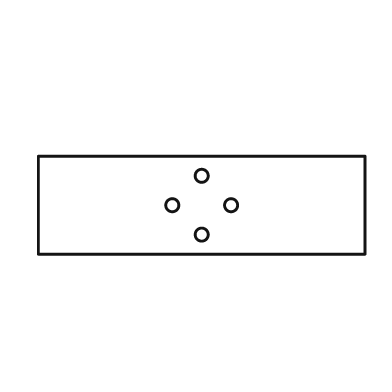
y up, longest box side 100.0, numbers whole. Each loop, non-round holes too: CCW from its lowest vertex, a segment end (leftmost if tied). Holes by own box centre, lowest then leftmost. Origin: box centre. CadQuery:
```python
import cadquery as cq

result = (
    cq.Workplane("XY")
    .moveTo(-50.0, -15.0)
    .lineTo(50.0, -15.0)
    .lineTo(50.0, 15.0)
    .lineTo(-50.0, 15.0)
    .close()
    .moveTo(0.0, -9.0)
    .circle(2.0)
    .moveTo(-9.0, 0.0)
    .circle(2.0)
    .moveTo(9.0, 0.0)
    .circle(2.0)
    .moveTo(0.0, 9.0)
    .circle(2.0)
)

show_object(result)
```